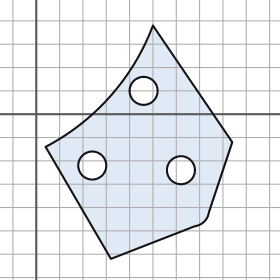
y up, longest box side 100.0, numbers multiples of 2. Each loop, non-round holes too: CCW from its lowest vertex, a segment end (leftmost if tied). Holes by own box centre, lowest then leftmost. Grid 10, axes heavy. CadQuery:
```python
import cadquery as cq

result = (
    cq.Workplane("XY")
    .moveTo(32.0, -62.0)
    .lineTo(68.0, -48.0)
    .threePointArc((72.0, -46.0), (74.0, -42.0))
    .lineTo(84.0, -12.0)
    .lineTo(50.0, 38.0)
    .threePointArc((32.0, 8.0), (4.0, -14.0))
    .close()
    .moveTo(62.0, -24.0)
    .circle(6.0)
    .moveTo(24.0, -22.0)
    .circle(6.0)
    .moveTo(46.0, 10.0)
    .circle(6.0)
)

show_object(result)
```